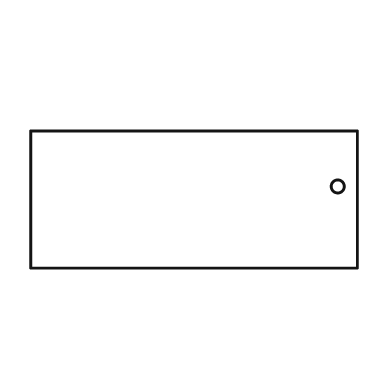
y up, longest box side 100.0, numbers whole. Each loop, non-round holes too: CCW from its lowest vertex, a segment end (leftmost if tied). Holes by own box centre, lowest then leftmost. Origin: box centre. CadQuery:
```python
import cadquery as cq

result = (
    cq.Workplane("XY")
    .moveTo(-50.0, -21.0)
    .lineTo(50.0, -21.0)
    .lineTo(50.0, 21.0)
    .lineTo(-50.0, 21.0)
    .close()
    .moveTo(44.0, 4.0)
    .circle(2.0)
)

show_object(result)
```